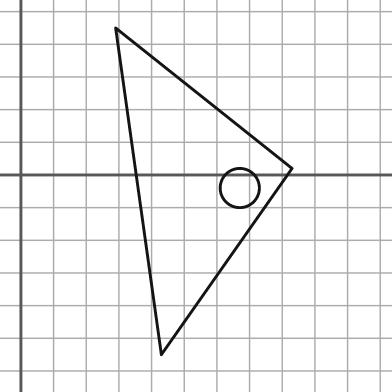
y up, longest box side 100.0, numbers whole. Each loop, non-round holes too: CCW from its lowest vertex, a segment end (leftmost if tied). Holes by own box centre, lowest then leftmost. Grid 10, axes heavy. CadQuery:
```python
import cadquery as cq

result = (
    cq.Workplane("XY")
    .moveTo(43.0, -55.0)
    .lineTo(83.0, 2.0)
    .lineTo(29.0, 45.0)
    .close()
    .moveTo(67.0, -4.0)
    .circle(6.0)
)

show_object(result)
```